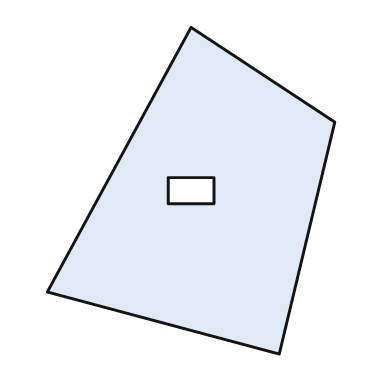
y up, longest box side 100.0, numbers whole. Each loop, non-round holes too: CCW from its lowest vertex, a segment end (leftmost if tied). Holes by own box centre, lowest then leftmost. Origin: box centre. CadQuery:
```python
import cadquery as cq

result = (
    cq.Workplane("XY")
    .moveTo(27.0, -50.0)
    .lineTo(44.0, 21.0)
    .lineTo(0.0, 50.0)
    .lineTo(-44.0, -31.0)
    .close()
    .moveTo(-7.0, -4.0)
    .lineTo(7.0, -4.0)
    .lineTo(7.0, 4.0)
    .lineTo(-7.0, 4.0)
    .close()
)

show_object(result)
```